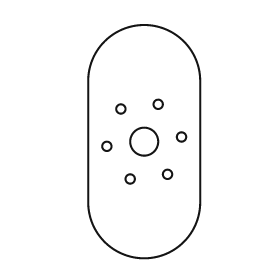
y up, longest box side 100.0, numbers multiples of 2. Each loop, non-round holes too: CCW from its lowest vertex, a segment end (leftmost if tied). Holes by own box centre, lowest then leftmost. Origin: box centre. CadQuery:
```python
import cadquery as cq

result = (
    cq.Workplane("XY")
    .moveTo(-24.0, -26.0)
    .threePointArc((0.0, -50.0), (24.0, -26.0))
    .lineTo(24.0, 26.0)
    .threePointArc((0.0, 50.0), (-24.0, 26.0))
    .close()
    .moveTo(-6.0, -16.0)
    .circle(2.0)
    .moveTo(10.0, -14.0)
    .circle(2.0)
    .moveTo(-16.0, -2.0)
    .circle(2.0)
    .moveTo(0.0, 0.0)
    .circle(6.0)
    .moveTo(16.0, 2.0)
    .circle(2.0)
    .moveTo(-10.0, 14.0)
    .circle(2.0)
    .moveTo(6.0, 16.0)
    .circle(2.0)
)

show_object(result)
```